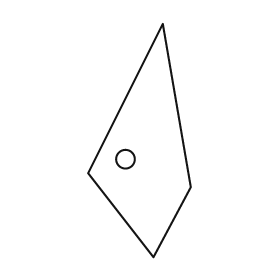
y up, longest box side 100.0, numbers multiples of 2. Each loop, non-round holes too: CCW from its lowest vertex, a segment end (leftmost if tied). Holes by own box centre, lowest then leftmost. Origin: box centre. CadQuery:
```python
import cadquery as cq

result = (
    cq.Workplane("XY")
    .moveTo(6.0, -50.0)
    .lineTo(22.0, -20.0)
    .lineTo(10.0, 50.0)
    .lineTo(-22.0, -14.0)
    .close()
    .moveTo(-6.0, -8.0)
    .circle(4.0)
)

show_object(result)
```